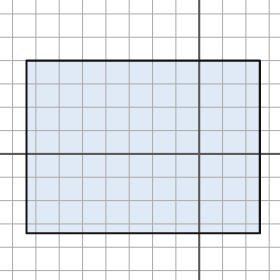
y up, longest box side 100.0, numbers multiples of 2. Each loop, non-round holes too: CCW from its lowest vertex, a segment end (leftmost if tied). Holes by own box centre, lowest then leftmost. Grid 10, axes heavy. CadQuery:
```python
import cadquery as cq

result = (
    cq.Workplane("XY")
    .moveTo(-74.0, -34.0)
    .lineTo(26.0, -34.0)
    .lineTo(26.0, 40.0)
    .lineTo(-74.0, 40.0)
    .close()
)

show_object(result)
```